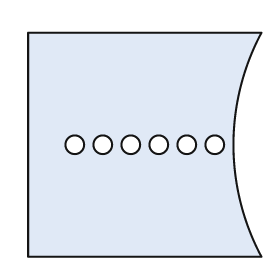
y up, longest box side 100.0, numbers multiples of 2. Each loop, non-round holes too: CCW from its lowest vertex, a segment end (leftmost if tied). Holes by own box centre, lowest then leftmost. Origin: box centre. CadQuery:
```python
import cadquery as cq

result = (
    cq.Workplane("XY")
    .moveTo(-50.0, -48.0)
    .lineTo(50.0, -48.0)
    .threePointArc((38.0, 0.0), (50.0, 48.0))
    .lineTo(-50.0, 48.0)
    .close()
    .moveTo(-30.0, 0.0)
    .circle(4.0)
    .moveTo(-18.0, 0.0)
    .circle(4.0)
    .moveTo(-6.0, 0.0)
    .circle(4.0)
    .moveTo(6.0, 0.0)
    .circle(4.0)
    .moveTo(18.0, 0.0)
    .circle(4.0)
    .moveTo(30.0, 0.0)
    .circle(4.0)
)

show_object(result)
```